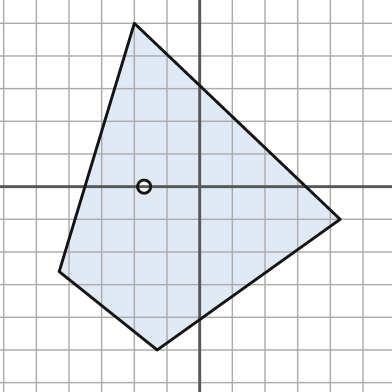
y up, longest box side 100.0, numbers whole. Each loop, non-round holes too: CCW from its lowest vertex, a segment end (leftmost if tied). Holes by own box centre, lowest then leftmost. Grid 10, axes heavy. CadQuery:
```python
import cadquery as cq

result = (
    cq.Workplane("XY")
    .moveTo(-13.0, -50.0)
    .lineTo(43.0, -10.0)
    .lineTo(-20.0, 50.0)
    .lineTo(-43.0, -26.0)
    .close()
    .moveTo(-17.0, 0.0)
    .circle(2.0)
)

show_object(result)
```